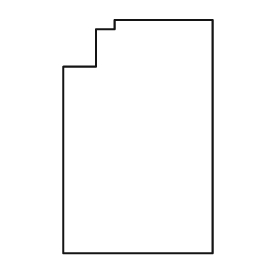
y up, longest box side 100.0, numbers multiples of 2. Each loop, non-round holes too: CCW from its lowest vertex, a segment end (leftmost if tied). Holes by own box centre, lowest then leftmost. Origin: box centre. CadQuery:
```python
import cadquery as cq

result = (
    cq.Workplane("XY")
    .moveTo(-32.0, -50.0)
    .lineTo(32.0, -50.0)
    .lineTo(32.0, 50.0)
    .lineTo(-10.0, 50.0)
    .lineTo(-10.0, 46.0)
    .lineTo(-18.0, 46.0)
    .lineTo(-18.0, 30.0)
    .lineTo(-32.0, 30.0)
    .close()
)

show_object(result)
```